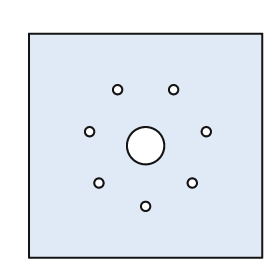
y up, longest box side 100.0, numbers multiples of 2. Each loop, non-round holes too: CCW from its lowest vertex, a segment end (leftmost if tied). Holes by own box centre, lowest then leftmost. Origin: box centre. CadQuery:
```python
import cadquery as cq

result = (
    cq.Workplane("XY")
    .moveTo(-50.0, -48.0)
    .lineTo(50.0, -48.0)
    .lineTo(50.0, 48.0)
    .lineTo(-50.0, 48.0)
    .close()
    .moveTo(0.0, -26.0)
    .circle(2.0)
    .moveTo(-20.0, -16.0)
    .circle(2.0)
    .moveTo(20.0, -16.0)
    .circle(2.0)
    .moveTo(0.0, 0.0)
    .circle(8.0)
    .moveTo(-24.0, 6.0)
    .circle(2.0)
    .moveTo(26.0, 6.0)
    .circle(2.0)
    .moveTo(-12.0, 24.0)
    .circle(2.0)
    .moveTo(12.0, 24.0)
    .circle(2.0)
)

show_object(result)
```